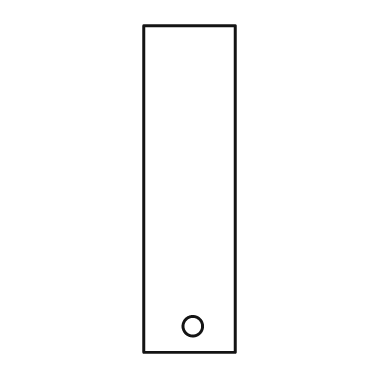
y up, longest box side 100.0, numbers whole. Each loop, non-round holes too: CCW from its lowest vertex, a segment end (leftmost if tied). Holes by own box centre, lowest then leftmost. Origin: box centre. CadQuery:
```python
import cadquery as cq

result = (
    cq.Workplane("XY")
    .moveTo(-14.0, -50.0)
    .lineTo(14.0, -50.0)
    .lineTo(14.0, 50.0)
    .lineTo(-14.0, 50.0)
    .close()
    .moveTo(1.0, -42.0)
    .circle(3.0)
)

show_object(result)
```